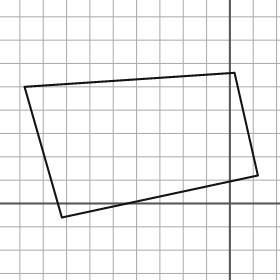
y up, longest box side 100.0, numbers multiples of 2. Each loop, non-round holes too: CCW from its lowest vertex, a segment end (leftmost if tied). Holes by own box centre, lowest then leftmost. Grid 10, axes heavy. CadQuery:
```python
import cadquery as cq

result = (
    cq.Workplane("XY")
    .moveTo(-72.0, -6.0)
    .lineTo(12.0, 12.0)
    .lineTo(2.0, 56.0)
    .lineTo(-88.0, 50.0)
    .close()
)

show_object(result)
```